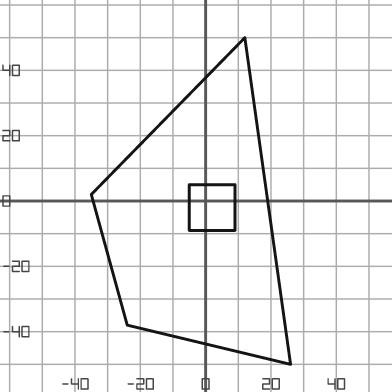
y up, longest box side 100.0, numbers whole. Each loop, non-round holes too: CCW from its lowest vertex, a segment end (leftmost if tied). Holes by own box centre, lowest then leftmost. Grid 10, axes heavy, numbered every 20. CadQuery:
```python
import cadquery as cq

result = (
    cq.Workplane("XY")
    .moveTo(26.0, -50.0)
    .lineTo(12.0, 50.0)
    .lineTo(-35.0, 2.0)
    .lineTo(-24.0, -38.0)
    .close()
    .moveTo(-5.0, -9.0)
    .lineTo(9.0, -9.0)
    .lineTo(9.0, 5.0)
    .lineTo(-5.0, 5.0)
    .close()
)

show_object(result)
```